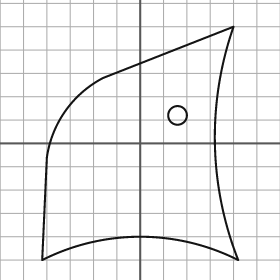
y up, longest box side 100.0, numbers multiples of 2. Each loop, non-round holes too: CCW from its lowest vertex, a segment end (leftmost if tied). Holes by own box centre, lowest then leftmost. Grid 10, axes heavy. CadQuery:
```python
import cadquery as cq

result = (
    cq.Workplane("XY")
    .moveTo(-42.0, -50.0)
    .threePointArc((0.0, -40.0), (42.0, -50.0))
    .threePointArc((32.0, 0.0), (40.0, 50.0))
    .lineTo(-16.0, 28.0)
    .threePointArc((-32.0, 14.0), (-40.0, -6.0))
    .close()
    .moveTo(16.0, 12.0)
    .circle(4.0)
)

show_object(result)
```